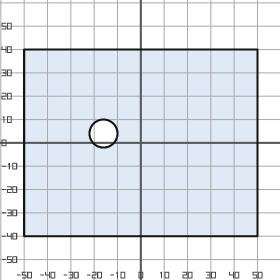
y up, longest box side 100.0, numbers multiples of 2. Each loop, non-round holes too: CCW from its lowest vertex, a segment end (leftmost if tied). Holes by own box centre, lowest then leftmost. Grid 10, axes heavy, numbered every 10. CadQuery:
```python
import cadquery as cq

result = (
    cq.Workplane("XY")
    .moveTo(-50.0, -40.0)
    .lineTo(50.0, -40.0)
    .lineTo(50.0, 40.0)
    .lineTo(-50.0, 40.0)
    .close()
    .moveTo(-16.0, 4.0)
    .circle(6.0)
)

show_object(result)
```